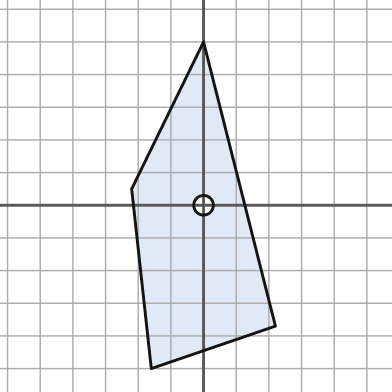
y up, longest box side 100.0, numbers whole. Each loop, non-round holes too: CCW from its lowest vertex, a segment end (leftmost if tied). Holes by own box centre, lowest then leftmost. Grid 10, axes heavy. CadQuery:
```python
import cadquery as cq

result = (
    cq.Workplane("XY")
    .moveTo(-16.0, -50.0)
    .lineTo(22.0, -37.0)
    .lineTo(0.0, 50.0)
    .lineTo(-22.0, 5.0)
    .close()
    .moveTo(0.0, 0.0)
    .circle(3.0)
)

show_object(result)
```